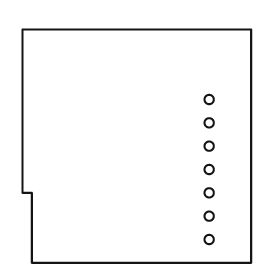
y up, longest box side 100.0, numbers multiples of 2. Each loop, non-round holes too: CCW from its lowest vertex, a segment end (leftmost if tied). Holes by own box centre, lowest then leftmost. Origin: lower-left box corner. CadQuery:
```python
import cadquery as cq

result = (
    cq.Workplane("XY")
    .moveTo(4.0, 0.0)
    .lineTo(98.0, 0.0)
    .lineTo(98.0, 100.0)
    .lineTo(0.0, 100.0)
    .lineTo(0.0, 30.0)
    .lineTo(4.0, 30.0)
    .close()
    .moveTo(80.0, 10.0)
    .circle(2.0)
    .moveTo(80.0, 20.0)
    .circle(2.0)
    .moveTo(80.0, 30.0)
    .circle(2.0)
    .moveTo(80.0, 40.0)
    .circle(2.0)
    .moveTo(80.0, 50.0)
    .circle(2.0)
    .moveTo(80.0, 60.0)
    .circle(2.0)
    .moveTo(80.0, 70.0)
    .circle(2.0)
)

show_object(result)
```